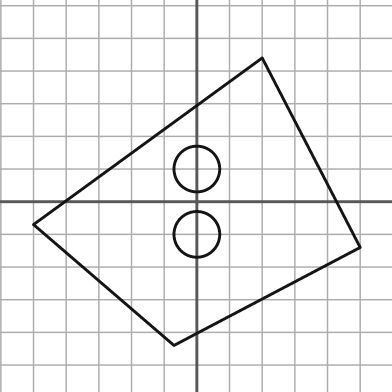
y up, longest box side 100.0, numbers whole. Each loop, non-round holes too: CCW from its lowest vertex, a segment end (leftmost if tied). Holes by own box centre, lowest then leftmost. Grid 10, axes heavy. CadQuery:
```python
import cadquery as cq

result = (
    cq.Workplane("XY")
    .moveTo(-7.0, -44.0)
    .lineTo(50.0, -14.0)
    .lineTo(20.0, 44.0)
    .lineTo(-50.0, -7.0)
    .close()
    .moveTo(0.0, -10.0)
    .circle(7.0)
    .moveTo(0.0, 10.0)
    .circle(7.0)
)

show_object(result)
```